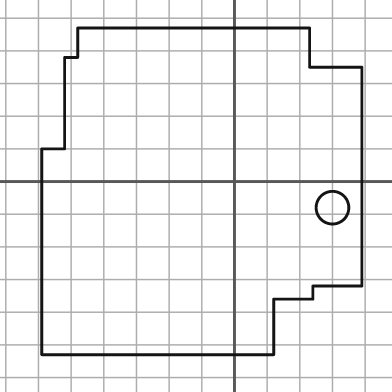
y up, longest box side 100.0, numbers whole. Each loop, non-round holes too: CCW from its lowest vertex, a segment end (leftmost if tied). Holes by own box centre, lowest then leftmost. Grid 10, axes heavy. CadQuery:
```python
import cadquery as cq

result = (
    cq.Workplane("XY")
    .moveTo(-59.0, -53.0)
    .lineTo(12.0, -53.0)
    .lineTo(12.0, -36.0)
    .lineTo(24.0, -36.0)
    .lineTo(24.0, -32.0)
    .lineTo(39.0, -32.0)
    .lineTo(39.0, 35.0)
    .lineTo(23.0, 35.0)
    .lineTo(23.0, 47.0)
    .lineTo(-48.0, 47.0)
    .lineTo(-48.0, 38.0)
    .lineTo(-52.0, 38.0)
    .lineTo(-52.0, 10.0)
    .lineTo(-59.0, 10.0)
    .close()
    .moveTo(30.0, -8.0)
    .circle(5.0)
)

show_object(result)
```